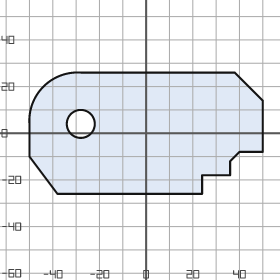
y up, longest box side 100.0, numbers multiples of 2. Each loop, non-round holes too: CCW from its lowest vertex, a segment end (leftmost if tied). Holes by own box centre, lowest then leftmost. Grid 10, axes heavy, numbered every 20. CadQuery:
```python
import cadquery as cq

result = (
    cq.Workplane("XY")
    .moveTo(-38.0, -26.0)
    .lineTo(24.0, -26.0)
    .lineTo(24.0, -18.0)
    .lineTo(36.0, -18.0)
    .lineTo(36.0, -12.0)
    .lineTo(40.0, -8.0)
    .lineTo(50.0, -8.0)
    .lineTo(50.0, 14.0)
    .lineTo(38.0, 26.0)
    .lineTo(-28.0, 26.0)
    .threePointArc((-44.0, 20.0), (-50.0, 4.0))
    .lineTo(-50.0, -10.0)
    .close()
    .moveTo(-28.0, 4.0)
    .circle(6.0)
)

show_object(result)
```